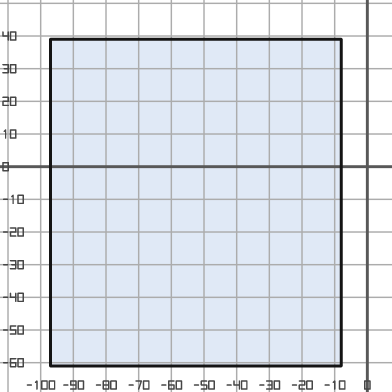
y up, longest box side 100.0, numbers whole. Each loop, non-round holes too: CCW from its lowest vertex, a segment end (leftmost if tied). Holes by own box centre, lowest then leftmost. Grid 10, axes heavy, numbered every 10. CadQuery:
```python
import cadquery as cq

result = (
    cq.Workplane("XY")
    .moveTo(-97.0, -61.0)
    .lineTo(-8.0, -61.0)
    .lineTo(-8.0, 39.0)
    .lineTo(-97.0, 39.0)
    .close()
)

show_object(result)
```